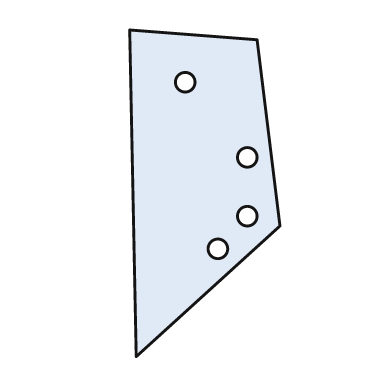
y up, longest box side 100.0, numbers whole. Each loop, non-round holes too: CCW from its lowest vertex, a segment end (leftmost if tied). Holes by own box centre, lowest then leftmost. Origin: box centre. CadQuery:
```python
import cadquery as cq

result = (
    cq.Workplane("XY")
    .moveTo(-21.0, -50.0)
    .lineTo(23.0, -10.0)
    .lineTo(16.0, 47.0)
    .lineTo(-23.0, 50.0)
    .close()
    .moveTo(4.0, -17.0)
    .circle(3.0)
    .moveTo(13.0, -7.0)
    .circle(3.0)
    .moveTo(13.0, 11.0)
    .circle(3.0)
    .moveTo(-6.0, 34.0)
    .circle(3.0)
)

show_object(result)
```